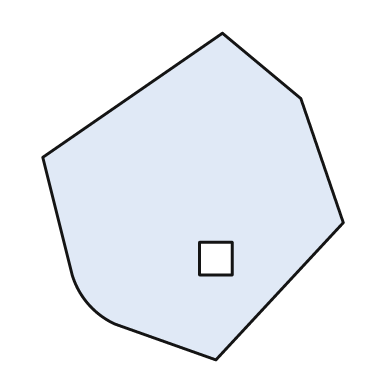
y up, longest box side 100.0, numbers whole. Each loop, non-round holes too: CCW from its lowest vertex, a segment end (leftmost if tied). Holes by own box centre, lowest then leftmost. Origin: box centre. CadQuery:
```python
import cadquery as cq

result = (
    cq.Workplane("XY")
    .moveTo(7.0, -50.0)
    .lineTo(46.0, -8.0)
    .lineTo(33.0, 30.0)
    .lineTo(9.0, 50.0)
    .lineTo(-46.0, 12.0)
    .lineTo(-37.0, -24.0)
    .threePointArc((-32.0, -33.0), (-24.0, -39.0))
    .close()
    .moveTo(2.0, -24.0)
    .lineTo(12.0, -24.0)
    .lineTo(12.0, -14.0)
    .lineTo(2.0, -14.0)
    .close()
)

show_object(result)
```